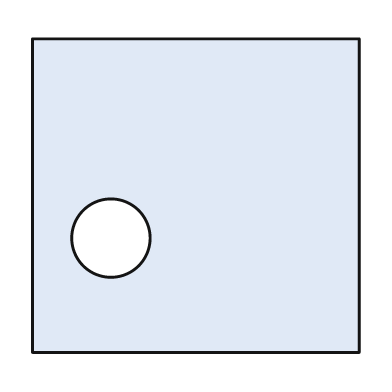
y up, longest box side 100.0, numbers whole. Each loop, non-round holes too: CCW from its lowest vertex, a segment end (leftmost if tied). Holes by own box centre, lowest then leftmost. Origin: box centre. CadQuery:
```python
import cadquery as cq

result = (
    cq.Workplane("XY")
    .moveTo(-50.0, -48.0)
    .lineTo(50.0, -48.0)
    .lineTo(50.0, 48.0)
    .lineTo(-50.0, 48.0)
    .close()
    .moveTo(-26.0, -13.0)
    .circle(12.0)
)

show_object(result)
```